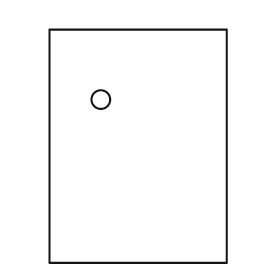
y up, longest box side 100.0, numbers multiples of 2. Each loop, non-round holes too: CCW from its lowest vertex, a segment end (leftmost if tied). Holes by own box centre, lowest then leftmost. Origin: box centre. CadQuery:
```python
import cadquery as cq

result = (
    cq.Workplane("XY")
    .moveTo(-38.0, -50.0)
    .lineTo(38.0, -50.0)
    .lineTo(38.0, 50.0)
    .lineTo(-38.0, 50.0)
    .close()
    .moveTo(-16.0, 20.0)
    .circle(4.0)
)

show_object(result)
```